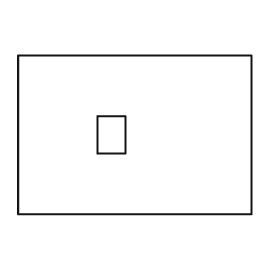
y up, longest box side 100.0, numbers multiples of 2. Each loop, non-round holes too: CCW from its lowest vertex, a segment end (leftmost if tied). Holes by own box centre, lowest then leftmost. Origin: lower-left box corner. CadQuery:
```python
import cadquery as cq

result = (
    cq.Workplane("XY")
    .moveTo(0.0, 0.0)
    .lineTo(100.0, 0.0)
    .lineTo(100.0, 68.0)
    .lineTo(0.0, 68.0)
    .close()
    .moveTo(34.0, 26.0)
    .lineTo(46.0, 26.0)
    .lineTo(46.0, 42.0)
    .lineTo(34.0, 42.0)
    .close()
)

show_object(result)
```